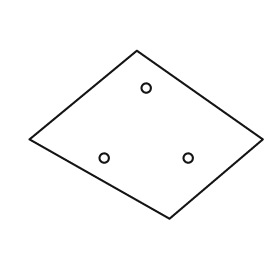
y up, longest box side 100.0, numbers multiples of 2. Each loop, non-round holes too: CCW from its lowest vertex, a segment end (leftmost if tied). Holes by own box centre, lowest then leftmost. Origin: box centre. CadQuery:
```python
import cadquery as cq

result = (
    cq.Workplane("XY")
    .moveTo(10.0, -36.0)
    .lineTo(50.0, -2.0)
    .lineTo(-4.0, 36.0)
    .lineTo(-50.0, -2.0)
    .close()
    .moveTo(-18.0, -10.0)
    .circle(2.0)
    .moveTo(18.0, -10.0)
    .circle(2.0)
    .moveTo(0.0, 20.0)
    .circle(2.0)
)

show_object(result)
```